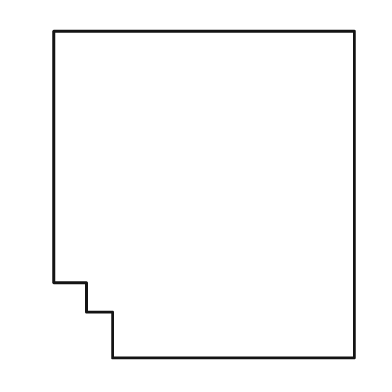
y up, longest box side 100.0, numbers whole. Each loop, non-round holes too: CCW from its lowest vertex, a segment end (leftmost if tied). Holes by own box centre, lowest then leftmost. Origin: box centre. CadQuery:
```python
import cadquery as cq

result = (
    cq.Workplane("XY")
    .moveTo(-28.0, -50.0)
    .lineTo(46.0, -50.0)
    .lineTo(46.0, 50.0)
    .lineTo(-46.0, 50.0)
    .lineTo(-46.0, -27.0)
    .lineTo(-36.0, -27.0)
    .lineTo(-36.0, -36.0)
    .lineTo(-28.0, -36.0)
    .close()
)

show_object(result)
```